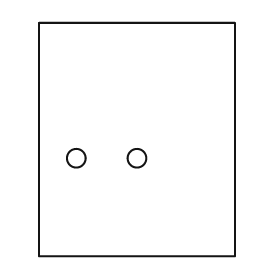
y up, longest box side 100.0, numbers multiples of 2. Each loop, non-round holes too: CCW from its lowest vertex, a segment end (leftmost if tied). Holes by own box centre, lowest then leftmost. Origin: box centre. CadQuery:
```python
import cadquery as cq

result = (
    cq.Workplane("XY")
    .moveTo(-42.0, -50.0)
    .lineTo(42.0, -50.0)
    .lineTo(42.0, 50.0)
    .lineTo(-42.0, 50.0)
    .close()
    .moveTo(-26.0, -8.0)
    .circle(4.0)
    .moveTo(0.0, -8.0)
    .circle(4.0)
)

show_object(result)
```